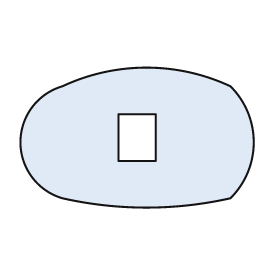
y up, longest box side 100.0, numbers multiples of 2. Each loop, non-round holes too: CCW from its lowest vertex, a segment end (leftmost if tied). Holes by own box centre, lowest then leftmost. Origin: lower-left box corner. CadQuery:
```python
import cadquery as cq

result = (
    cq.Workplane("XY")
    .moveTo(18.0, 4.0)
    .threePointArc((54.0, 0.0), (90.0, 4.0))
    .threePointArc((100.0, 28.0), (90.0, 52.0))
    .threePointArc((54.0, 60.0), (18.0, 52.0))
    .threePointArc((0.0, 28.0), (18.0, 4.0))
    .close()
    .moveTo(42.0, 20.0)
    .lineTo(58.0, 20.0)
    .lineTo(58.0, 40.0)
    .lineTo(42.0, 40.0)
    .close()
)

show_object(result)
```